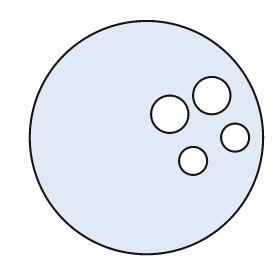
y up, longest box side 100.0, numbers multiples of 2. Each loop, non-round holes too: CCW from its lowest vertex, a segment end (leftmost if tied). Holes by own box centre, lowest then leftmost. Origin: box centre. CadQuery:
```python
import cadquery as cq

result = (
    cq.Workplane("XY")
    .moveTo(0.0, 0.0)
    .circle(50.0)
    .moveTo(20.0, -10.0)
    .circle(6.0)
    .moveTo(38.0, 0.0)
    .circle(6.0)
    .moveTo(10.0, 10.0)
    .circle(8.0)
    .moveTo(28.0, 18.0)
    .circle(8.0)
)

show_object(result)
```